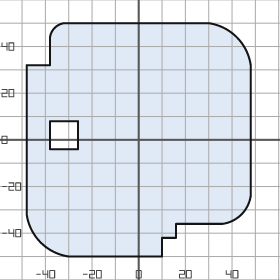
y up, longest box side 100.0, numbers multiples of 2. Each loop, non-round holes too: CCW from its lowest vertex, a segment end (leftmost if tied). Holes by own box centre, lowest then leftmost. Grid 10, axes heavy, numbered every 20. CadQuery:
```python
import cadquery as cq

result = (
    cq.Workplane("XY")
    .moveTo(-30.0, -50.0)
    .lineTo(10.0, -50.0)
    .lineTo(10.0, -42.0)
    .lineTo(16.0, -42.0)
    .lineTo(16.0, -36.0)
    .lineTo(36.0, -36.0)
    .threePointArc((44.0, -32.0), (48.0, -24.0))
    .lineTo(48.0, 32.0)
    .threePointArc((42.0, 44.0), (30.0, 50.0))
    .lineTo(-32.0, 50.0)
    .threePointArc((-36.0, 48.0), (-38.0, 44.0))
    .lineTo(-38.0, 32.0)
    .lineTo(-48.0, 32.0)
    .lineTo(-48.0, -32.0)
    .threePointArc((-42.0, -44.0), (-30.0, -50.0))
    .close()
    .moveTo(-38.0, -4.0)
    .lineTo(-26.0, -4.0)
    .lineTo(-26.0, 8.0)
    .lineTo(-38.0, 8.0)
    .close()
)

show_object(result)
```